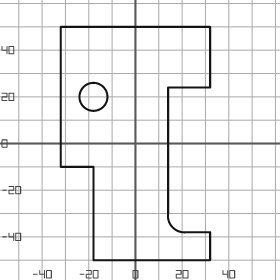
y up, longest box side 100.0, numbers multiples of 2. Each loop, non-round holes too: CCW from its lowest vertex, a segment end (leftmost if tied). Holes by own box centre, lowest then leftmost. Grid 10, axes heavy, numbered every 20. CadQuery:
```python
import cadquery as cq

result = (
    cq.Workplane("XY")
    .moveTo(-18.0, -50.0)
    .lineTo(32.0, -50.0)
    .lineTo(32.0, -38.0)
    .lineTo(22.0, -38.0)
    .threePointArc((16.0, -36.0), (14.0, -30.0))
    .lineTo(14.0, 24.0)
    .lineTo(32.0, 24.0)
    .lineTo(32.0, 50.0)
    .lineTo(-32.0, 50.0)
    .lineTo(-32.0, -10.0)
    .lineTo(-18.0, -10.0)
    .close()
    .moveTo(-18.0, 20.0)
    .circle(6.0)
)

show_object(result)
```